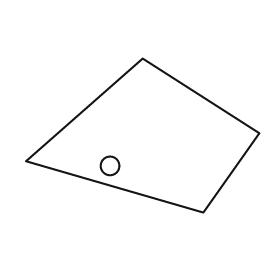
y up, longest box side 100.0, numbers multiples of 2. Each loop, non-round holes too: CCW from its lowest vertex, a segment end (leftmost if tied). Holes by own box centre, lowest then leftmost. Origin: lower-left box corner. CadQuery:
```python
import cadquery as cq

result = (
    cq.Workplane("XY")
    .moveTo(76.0, 0.0)
    .lineTo(100.0, 34.0)
    .lineTo(50.0, 66.0)
    .lineTo(0.0, 22.0)
    .close()
    .moveTo(36.0, 20.0)
    .circle(4.0)
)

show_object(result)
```